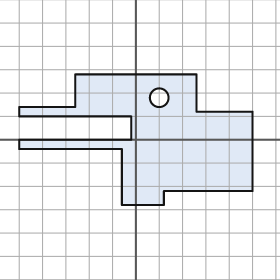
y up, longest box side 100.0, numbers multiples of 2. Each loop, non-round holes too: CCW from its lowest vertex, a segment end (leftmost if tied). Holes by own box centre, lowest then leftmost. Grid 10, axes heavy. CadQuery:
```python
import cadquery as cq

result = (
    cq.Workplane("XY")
    .moveTo(-6.0, -28.0)
    .lineTo(12.0, -28.0)
    .lineTo(12.0, -22.0)
    .lineTo(50.0, -22.0)
    .lineTo(50.0, 12.0)
    .lineTo(26.0, 12.0)
    .lineTo(26.0, 28.0)
    .lineTo(-26.0, 28.0)
    .lineTo(-26.0, 14.0)
    .lineTo(-50.0, 14.0)
    .lineTo(-50.0, 10.0)
    .lineTo(-2.0, 10.0)
    .lineTo(-2.0, 0.0)
    .lineTo(-50.0, 0.0)
    .lineTo(-50.0, -4.0)
    .lineTo(-6.0, -4.0)
    .close()
    .moveTo(10.0, 18.0)
    .circle(4.0)
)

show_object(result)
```